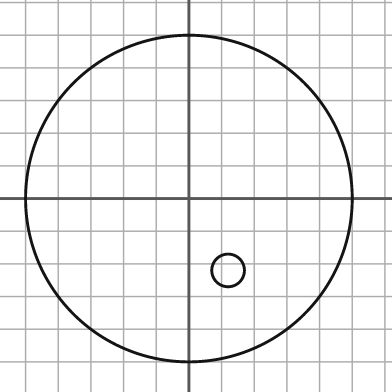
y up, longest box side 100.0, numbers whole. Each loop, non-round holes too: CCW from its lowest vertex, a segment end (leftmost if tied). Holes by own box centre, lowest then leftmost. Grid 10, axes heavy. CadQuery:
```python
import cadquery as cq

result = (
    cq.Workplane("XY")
    .moveTo(0.0, 0.0)
    .circle(50.0)
    .moveTo(12.0, -22.0)
    .circle(5.0)
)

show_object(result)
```